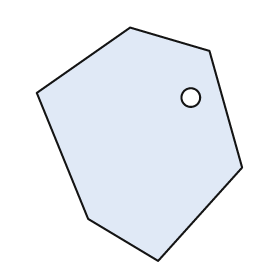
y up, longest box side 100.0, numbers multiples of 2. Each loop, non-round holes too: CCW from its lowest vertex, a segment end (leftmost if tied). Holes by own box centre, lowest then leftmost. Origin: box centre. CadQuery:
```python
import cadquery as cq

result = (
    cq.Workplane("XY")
    .moveTo(8.0, -50.0)
    .lineTo(44.0, -10.0)
    .lineTo(30.0, 40.0)
    .lineTo(-4.0, 50.0)
    .lineTo(-44.0, 22.0)
    .lineTo(-22.0, -32.0)
    .close()
    .moveTo(22.0, 20.0)
    .circle(4.0)
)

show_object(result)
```